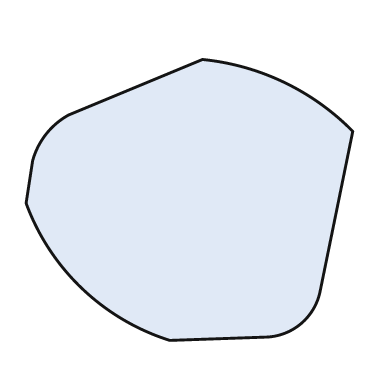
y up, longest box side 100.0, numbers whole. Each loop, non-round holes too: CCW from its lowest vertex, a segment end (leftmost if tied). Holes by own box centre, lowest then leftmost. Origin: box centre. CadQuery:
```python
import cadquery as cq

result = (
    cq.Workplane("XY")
    .moveTo(-6.0, -43.0)
    .lineTo(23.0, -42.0)
    .threePointArc((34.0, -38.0), (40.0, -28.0))
    .lineTo(50.0, 21.0)
    .threePointArc((29.0, 36.0), (4.0, 43.0))
    .lineTo(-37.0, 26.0)
    .threePointArc((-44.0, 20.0), (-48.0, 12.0))
    .lineTo(-50.0, -1.0)
    .threePointArc((-33.0, -27.0), (-6.0, -43.0))
    .close()
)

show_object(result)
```